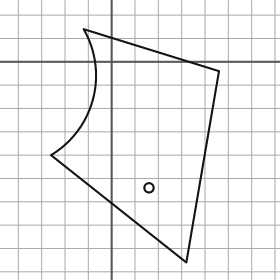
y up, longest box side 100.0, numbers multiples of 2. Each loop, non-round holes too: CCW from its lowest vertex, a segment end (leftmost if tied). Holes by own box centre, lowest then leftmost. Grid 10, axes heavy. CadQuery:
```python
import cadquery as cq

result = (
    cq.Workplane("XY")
    .moveTo(32.0, -86.0)
    .lineTo(46.0, -4.0)
    .lineTo(-12.0, 14.0)
    .threePointArc((-8.0, -16.0), (-26.0, -40.0))
    .close()
    .moveTo(16.0, -54.0)
    .circle(2.0)
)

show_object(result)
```